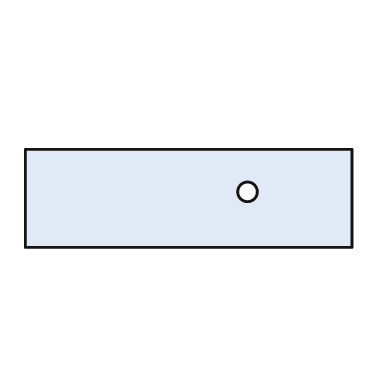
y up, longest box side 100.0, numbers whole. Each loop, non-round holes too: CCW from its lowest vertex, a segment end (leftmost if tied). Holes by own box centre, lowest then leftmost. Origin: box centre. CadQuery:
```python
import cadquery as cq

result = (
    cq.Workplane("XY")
    .moveTo(-50.0, -15.0)
    .lineTo(50.0, -15.0)
    .lineTo(50.0, 15.0)
    .lineTo(-50.0, 15.0)
    .close()
    .moveTo(18.0, 2.0)
    .circle(3.0)
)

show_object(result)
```